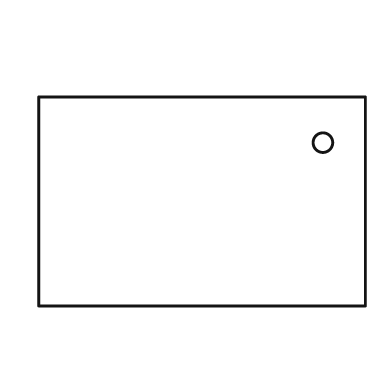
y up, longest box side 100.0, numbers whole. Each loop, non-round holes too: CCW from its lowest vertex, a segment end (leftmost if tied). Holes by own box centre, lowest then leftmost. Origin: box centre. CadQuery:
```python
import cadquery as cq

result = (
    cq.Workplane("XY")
    .moveTo(-50.0, -32.0)
    .lineTo(50.0, -32.0)
    .lineTo(50.0, 32.0)
    .lineTo(-50.0, 32.0)
    .close()
    .moveTo(37.0, 18.0)
    .circle(3.0)
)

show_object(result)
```